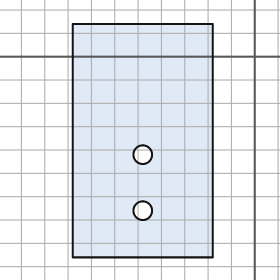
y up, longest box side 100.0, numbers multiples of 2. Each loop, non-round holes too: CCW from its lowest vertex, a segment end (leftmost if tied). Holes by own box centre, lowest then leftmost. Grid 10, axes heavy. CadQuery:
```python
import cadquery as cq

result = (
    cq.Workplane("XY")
    .moveTo(-78.0, -86.0)
    .lineTo(-18.0, -86.0)
    .lineTo(-18.0, 14.0)
    .lineTo(-78.0, 14.0)
    .close()
    .moveTo(-48.0, -66.0)
    .circle(4.0)
    .moveTo(-48.0, -42.0)
    .circle(4.0)
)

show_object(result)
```